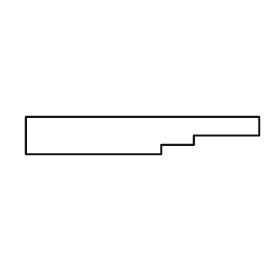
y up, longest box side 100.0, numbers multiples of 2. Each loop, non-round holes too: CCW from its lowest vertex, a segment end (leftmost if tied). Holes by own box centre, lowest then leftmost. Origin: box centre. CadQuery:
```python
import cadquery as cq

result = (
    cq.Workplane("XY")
    .moveTo(-50.0, -8.0)
    .lineTo(8.0, -8.0)
    .lineTo(8.0, -4.0)
    .lineTo(22.0, -4.0)
    .lineTo(22.0, 0.0)
    .lineTo(50.0, 0.0)
    .lineTo(50.0, 8.0)
    .lineTo(-50.0, 8.0)
    .close()
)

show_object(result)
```